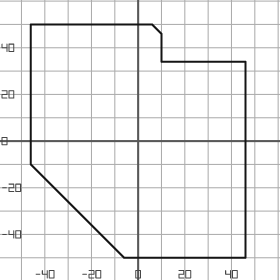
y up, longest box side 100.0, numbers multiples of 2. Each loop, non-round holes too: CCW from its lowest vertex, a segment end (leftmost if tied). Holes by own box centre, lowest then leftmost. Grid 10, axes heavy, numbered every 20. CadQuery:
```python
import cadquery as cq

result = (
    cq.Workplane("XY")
    .moveTo(-6.0, -50.0)
    .lineTo(46.0, -50.0)
    .lineTo(46.0, 34.0)
    .lineTo(10.0, 34.0)
    .lineTo(10.0, 46.0)
    .lineTo(6.0, 50.0)
    .lineTo(-46.0, 50.0)
    .lineTo(-46.0, -10.0)
    .close()
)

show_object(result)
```